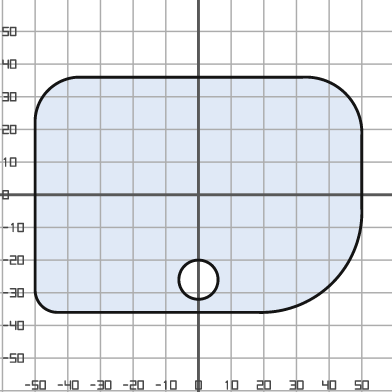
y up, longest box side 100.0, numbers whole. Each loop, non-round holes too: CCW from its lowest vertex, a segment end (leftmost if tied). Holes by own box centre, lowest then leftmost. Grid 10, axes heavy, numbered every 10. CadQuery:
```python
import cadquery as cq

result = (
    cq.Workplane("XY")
    .moveTo(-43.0, -36.0)
    .lineTo(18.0, -36.0)
    .threePointArc((41.0, -27.0), (50.0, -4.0))
    .lineTo(50.0, 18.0)
    .threePointArc((45.0, 31.0), (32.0, 36.0))
    .lineTo(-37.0, 36.0)
    .threePointArc((-46.0, 32.0), (-50.0, 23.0))
    .lineTo(-50.0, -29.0)
    .threePointArc((-48.0, -34.0), (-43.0, -36.0))
    .close()
    .moveTo(0.0, -26.0)
    .circle(6.0)
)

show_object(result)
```